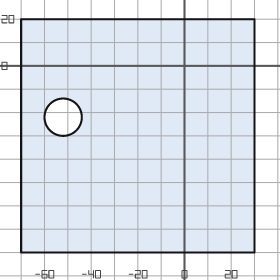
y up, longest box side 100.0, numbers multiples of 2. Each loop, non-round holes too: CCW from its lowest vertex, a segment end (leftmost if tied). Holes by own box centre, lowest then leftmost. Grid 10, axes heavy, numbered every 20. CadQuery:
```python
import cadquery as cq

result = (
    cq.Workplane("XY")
    .moveTo(-70.0, -80.0)
    .lineTo(30.0, -80.0)
    .lineTo(30.0, 20.0)
    .lineTo(-70.0, 20.0)
    .close()
    .moveTo(-52.0, -22.0)
    .circle(8.0)
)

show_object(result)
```